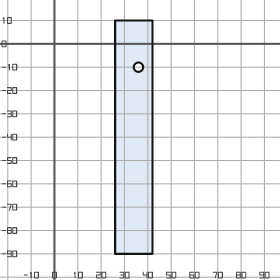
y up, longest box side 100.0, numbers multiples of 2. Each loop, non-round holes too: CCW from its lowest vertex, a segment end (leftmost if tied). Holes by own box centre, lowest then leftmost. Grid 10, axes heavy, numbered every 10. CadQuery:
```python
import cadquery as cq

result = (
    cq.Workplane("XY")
    .moveTo(26.0, -90.0)
    .lineTo(42.0, -90.0)
    .lineTo(42.0, 10.0)
    .lineTo(26.0, 10.0)
    .close()
    .moveTo(36.0, -10.0)
    .circle(2.0)
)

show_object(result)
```